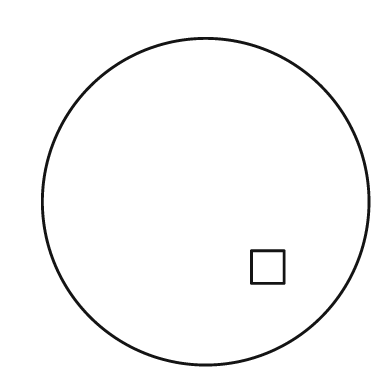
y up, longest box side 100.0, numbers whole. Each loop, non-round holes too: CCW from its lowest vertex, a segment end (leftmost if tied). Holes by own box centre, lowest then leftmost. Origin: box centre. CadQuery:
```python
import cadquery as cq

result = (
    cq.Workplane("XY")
    .moveTo(0.0, 0.0)
    .circle(50.0)
    .moveTo(14.0, -25.0)
    .lineTo(24.0, -25.0)
    .lineTo(24.0, -15.0)
    .lineTo(14.0, -15.0)
    .close()
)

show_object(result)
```